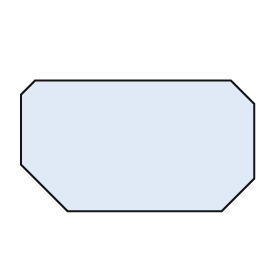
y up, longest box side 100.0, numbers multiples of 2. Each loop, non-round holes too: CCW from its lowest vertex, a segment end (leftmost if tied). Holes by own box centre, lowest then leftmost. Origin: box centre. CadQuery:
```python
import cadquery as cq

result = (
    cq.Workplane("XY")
    .moveTo(-30.0, -28.0)
    .lineTo(36.0, -28.0)
    .lineTo(50.0, -14.0)
    .lineTo(50.0, 18.0)
    .lineTo(40.0, 28.0)
    .lineTo(-44.0, 28.0)
    .lineTo(-50.0, 22.0)
    .lineTo(-50.0, -8.0)
    .close()
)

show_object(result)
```